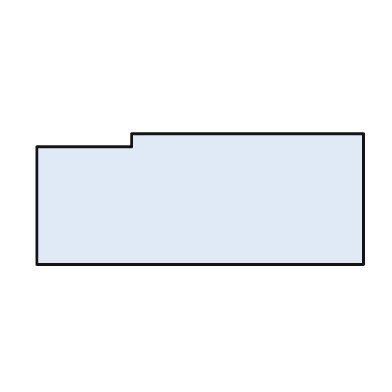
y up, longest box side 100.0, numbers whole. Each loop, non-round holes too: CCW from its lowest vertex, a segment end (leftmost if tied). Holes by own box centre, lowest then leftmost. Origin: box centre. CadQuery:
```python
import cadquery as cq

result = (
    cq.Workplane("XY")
    .moveTo(-50.0, -20.0)
    .lineTo(50.0, -20.0)
    .lineTo(50.0, 20.0)
    .lineTo(-21.0, 20.0)
    .lineTo(-21.0, 16.0)
    .lineTo(-50.0, 16.0)
    .close()
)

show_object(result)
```